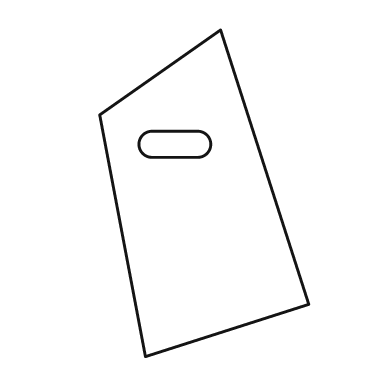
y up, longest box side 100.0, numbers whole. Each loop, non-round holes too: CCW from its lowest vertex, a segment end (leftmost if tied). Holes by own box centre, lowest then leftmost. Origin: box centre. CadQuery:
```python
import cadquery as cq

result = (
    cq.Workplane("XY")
    .moveTo(-18.0, -50.0)
    .lineTo(32.0, -34.0)
    .lineTo(5.0, 50.0)
    .lineTo(-32.0, 24.0)
    .close()
    .moveTo(-16.0, 11.0)
    .lineTo(-2.0, 11.0)
    .threePointArc((2.0, 15.0), (-2.0, 19.0))
    .lineTo(-16.0, 19.0)
    .threePointArc((-20.0, 15.0), (-16.0, 11.0))
    .close()
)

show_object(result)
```